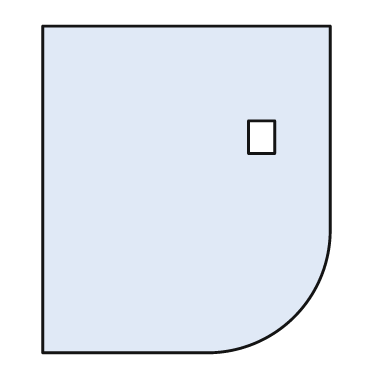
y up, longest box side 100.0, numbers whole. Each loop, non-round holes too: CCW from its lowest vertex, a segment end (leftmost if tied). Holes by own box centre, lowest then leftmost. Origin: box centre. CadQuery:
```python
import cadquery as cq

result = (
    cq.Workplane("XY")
    .moveTo(-44.0, -50.0)
    .lineTo(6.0, -50.0)
    .threePointArc((33.0, -39.0), (44.0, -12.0))
    .lineTo(44.0, 50.0)
    .lineTo(-44.0, 50.0)
    .close()
    .moveTo(19.0, 11.0)
    .lineTo(27.0, 11.0)
    .lineTo(27.0, 21.0)
    .lineTo(19.0, 21.0)
    .close()
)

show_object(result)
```